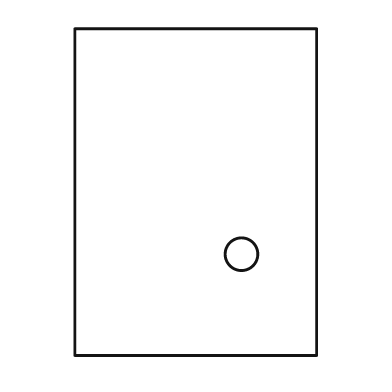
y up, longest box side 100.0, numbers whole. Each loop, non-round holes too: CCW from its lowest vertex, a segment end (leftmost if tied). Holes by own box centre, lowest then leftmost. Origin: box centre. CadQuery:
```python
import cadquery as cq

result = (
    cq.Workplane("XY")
    .moveTo(-37.0, -50.0)
    .lineTo(37.0, -50.0)
    .lineTo(37.0, 50.0)
    .lineTo(-37.0, 50.0)
    .close()
    .moveTo(14.0, -19.0)
    .circle(5.0)
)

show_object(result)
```